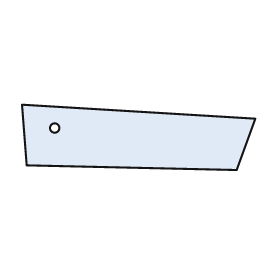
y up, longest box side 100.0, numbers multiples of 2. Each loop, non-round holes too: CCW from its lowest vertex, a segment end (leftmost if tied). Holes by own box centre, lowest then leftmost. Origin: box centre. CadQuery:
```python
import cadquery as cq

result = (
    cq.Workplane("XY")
    .moveTo(42.0, -14.0)
    .lineTo(50.0, 8.0)
    .lineTo(-50.0, 14.0)
    .lineTo(-48.0, -12.0)
    .close()
    .moveTo(-36.0, 4.0)
    .circle(2.0)
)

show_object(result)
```